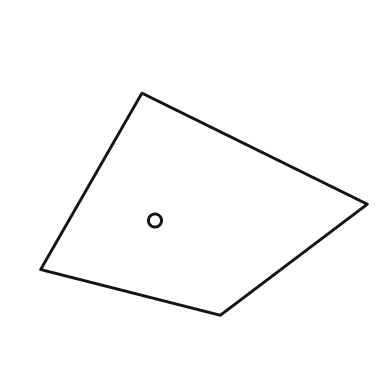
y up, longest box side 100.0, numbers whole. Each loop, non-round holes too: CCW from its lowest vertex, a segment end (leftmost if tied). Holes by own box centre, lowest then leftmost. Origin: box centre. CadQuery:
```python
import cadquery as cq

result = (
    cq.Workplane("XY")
    .moveTo(5.0, -34.0)
    .lineTo(50.0, 0.0)
    .lineTo(-19.0, 34.0)
    .lineTo(-50.0, -20.0)
    .close()
    .moveTo(-15.0, -5.0)
    .circle(2.0)
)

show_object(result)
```